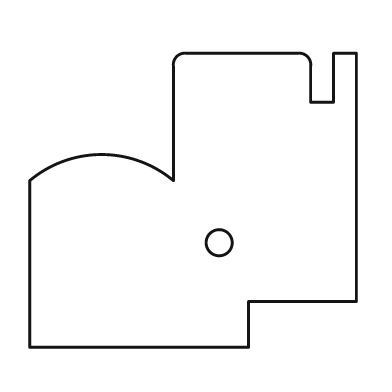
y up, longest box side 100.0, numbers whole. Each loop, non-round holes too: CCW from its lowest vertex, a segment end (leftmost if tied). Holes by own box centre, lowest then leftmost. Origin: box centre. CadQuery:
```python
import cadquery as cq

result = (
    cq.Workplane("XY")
    .moveTo(-50.0, -45.0)
    .lineTo(17.0, -45.0)
    .lineTo(17.0, -31.0)
    .lineTo(50.0, -31.0)
    .lineTo(50.0, 45.0)
    .lineTo(43.0, 45.0)
    .lineTo(43.0, 30.0)
    .lineTo(36.0, 30.0)
    .lineTo(36.0, 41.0)
    .threePointArc((35.0, 44.0), (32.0, 45.0))
    .lineTo(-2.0, 45.0)
    .threePointArc((-5.0, 44.0), (-6.0, 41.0))
    .lineTo(-6.0, 6.0)
    .threePointArc((-28.0, 14.0), (-50.0, 6.0))
    .close()
    .moveTo(8.0, -13.0)
    .circle(4.0)
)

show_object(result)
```